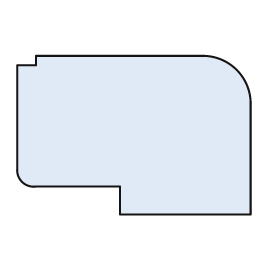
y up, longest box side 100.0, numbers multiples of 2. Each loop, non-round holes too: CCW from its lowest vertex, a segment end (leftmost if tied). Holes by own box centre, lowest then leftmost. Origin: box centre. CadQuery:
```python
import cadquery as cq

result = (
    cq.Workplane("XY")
    .moveTo(-6.0, -34.0)
    .lineTo(50.0, -34.0)
    .lineTo(50.0, 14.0)
    .threePointArc((44.0, 28.0), (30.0, 34.0))
    .lineTo(-42.0, 34.0)
    .lineTo(-42.0, 30.0)
    .lineTo(-50.0, 30.0)
    .lineTo(-50.0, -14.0)
    .threePointArc((-48.0, -20.0), (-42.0, -22.0))
    .lineTo(-6.0, -22.0)
    .close()
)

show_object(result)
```